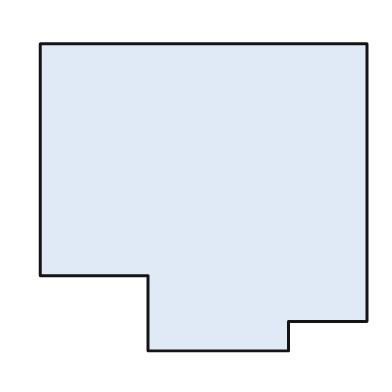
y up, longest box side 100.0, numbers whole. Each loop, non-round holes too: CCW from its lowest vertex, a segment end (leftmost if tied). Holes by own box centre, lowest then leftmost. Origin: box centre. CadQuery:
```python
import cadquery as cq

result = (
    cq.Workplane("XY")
    .moveTo(-17.0, -47.0)
    .lineTo(26.0, -47.0)
    .lineTo(26.0, -38.0)
    .lineTo(50.0, -38.0)
    .lineTo(50.0, 47.0)
    .lineTo(-50.0, 47.0)
    .lineTo(-50.0, -24.0)
    .lineTo(-17.0, -24.0)
    .close()
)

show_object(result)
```